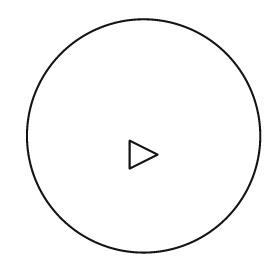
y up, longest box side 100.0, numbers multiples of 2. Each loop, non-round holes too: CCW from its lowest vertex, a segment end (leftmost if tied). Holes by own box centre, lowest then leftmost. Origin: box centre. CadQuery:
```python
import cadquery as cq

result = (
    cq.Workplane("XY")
    .moveTo(0.0, 0.0)
    .circle(50.0)
    .moveTo(-6.0, -14.0)
    .lineTo(6.0, -8.0)
    .lineTo(-6.0, -2.0)
    .close()
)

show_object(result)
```